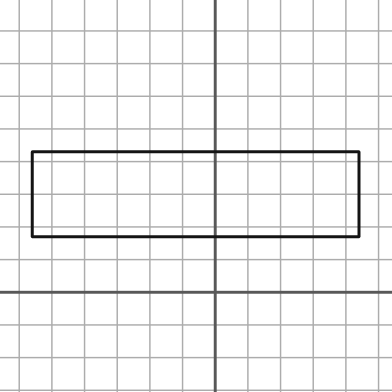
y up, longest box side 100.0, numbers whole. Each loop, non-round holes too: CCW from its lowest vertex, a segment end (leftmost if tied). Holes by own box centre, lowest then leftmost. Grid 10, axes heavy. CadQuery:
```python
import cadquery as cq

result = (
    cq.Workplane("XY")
    .moveTo(-56.0, 17.0)
    .lineTo(44.0, 17.0)
    .lineTo(44.0, 43.0)
    .lineTo(-56.0, 43.0)
    .close()
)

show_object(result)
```